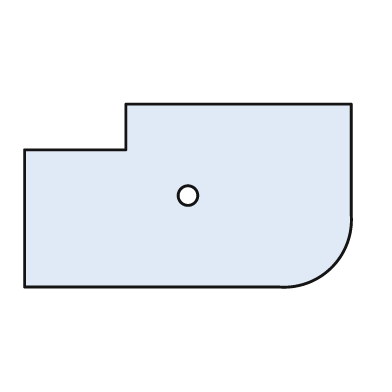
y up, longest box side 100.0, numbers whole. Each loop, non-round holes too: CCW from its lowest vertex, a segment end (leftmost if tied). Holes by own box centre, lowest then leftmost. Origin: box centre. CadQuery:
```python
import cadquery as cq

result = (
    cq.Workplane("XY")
    .moveTo(-50.0, -28.0)
    .lineTo(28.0, -28.0)
    .threePointArc((44.0, -22.0), (50.0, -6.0))
    .lineTo(50.0, 28.0)
    .lineTo(-19.0, 28.0)
    .lineTo(-19.0, 14.0)
    .lineTo(-50.0, 14.0)
    .close()
    .moveTo(0.0, 0.0)
    .circle(3.0)
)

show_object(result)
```